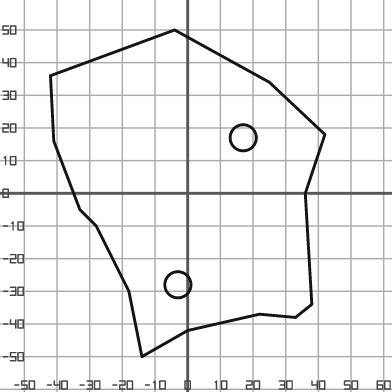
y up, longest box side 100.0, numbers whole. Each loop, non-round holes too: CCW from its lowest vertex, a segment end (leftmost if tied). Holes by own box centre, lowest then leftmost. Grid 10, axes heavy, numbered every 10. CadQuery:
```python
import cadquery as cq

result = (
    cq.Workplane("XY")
    .moveTo(-14.0, -50.0)
    .lineTo(0.0, -42.0)
    .lineTo(22.0, -37.0)
    .lineTo(33.0, -38.0)
    .lineTo(38.0, -34.0)
    .lineTo(36.0, 0.0)
    .lineTo(42.0, 18.0)
    .lineTo(25.0, 34.0)
    .lineTo(-4.0, 50.0)
    .lineTo(-42.0, 36.0)
    .lineTo(-41.0, 16.0)
    .lineTo(-33.0, -5.0)
    .lineTo(-28.0, -10.0)
    .lineTo(-18.0, -30.0)
    .close()
    .moveTo(-3.0, -28.0)
    .circle(4.0)
    .moveTo(17.0, 17.0)
    .circle(4.0)
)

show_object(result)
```